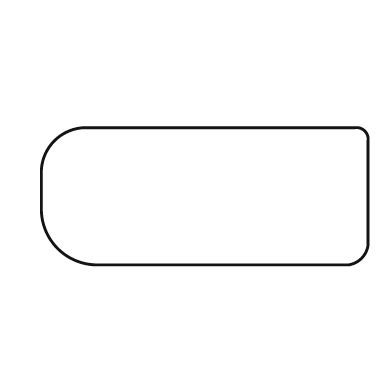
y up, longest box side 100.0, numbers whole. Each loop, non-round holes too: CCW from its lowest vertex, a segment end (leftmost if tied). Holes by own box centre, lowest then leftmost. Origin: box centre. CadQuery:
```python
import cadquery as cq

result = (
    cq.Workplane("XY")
    .moveTo(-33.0, -21.0)
    .lineTo(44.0, -21.0)
    .threePointArc((48.0, -19.0), (50.0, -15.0))
    .lineTo(50.0, 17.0)
    .threePointArc((49.0, 20.0), (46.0, 21.0))
    .lineTo(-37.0, 21.0)
    .threePointArc((-46.0, 17.0), (-50.0, 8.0))
    .lineTo(-50.0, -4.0)
    .threePointArc((-45.0, -16.0), (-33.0, -21.0))
    .close()
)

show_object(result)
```